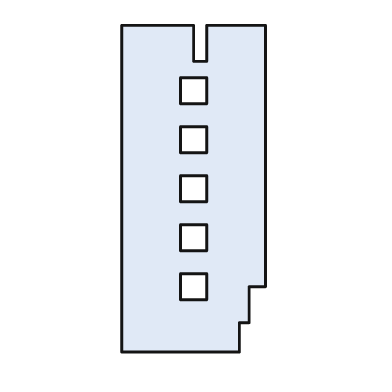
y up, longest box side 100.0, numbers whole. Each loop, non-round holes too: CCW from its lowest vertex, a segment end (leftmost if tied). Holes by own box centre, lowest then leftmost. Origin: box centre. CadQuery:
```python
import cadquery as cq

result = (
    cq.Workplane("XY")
    .moveTo(-22.0, -50.0)
    .lineTo(14.0, -50.0)
    .lineTo(14.0, -41.0)
    .lineTo(17.0, -41.0)
    .lineTo(17.0, -30.0)
    .lineTo(22.0, -30.0)
    .lineTo(22.0, 50.0)
    .lineTo(4.0, 50.0)
    .lineTo(4.0, 39.0)
    .lineTo(0.0, 39.0)
    .lineTo(0.0, 50.0)
    .lineTo(-22.0, 50.0)
    .close()
    .moveTo(-4.0, -34.0)
    .lineTo(4.0, -34.0)
    .lineTo(4.0, -26.0)
    .lineTo(-4.0, -26.0)
    .close()
    .moveTo(-4.0, -19.0)
    .lineTo(4.0, -19.0)
    .lineTo(4.0, -11.0)
    .lineTo(-4.0, -11.0)
    .close()
    .moveTo(-4.0, -4.0)
    .lineTo(4.0, -4.0)
    .lineTo(4.0, 4.0)
    .lineTo(-4.0, 4.0)
    .close()
    .moveTo(-4.0, 11.0)
    .lineTo(4.0, 11.0)
    .lineTo(4.0, 19.0)
    .lineTo(-4.0, 19.0)
    .close()
    .moveTo(-4.0, 26.0)
    .lineTo(4.0, 26.0)
    .lineTo(4.0, 34.0)
    .lineTo(-4.0, 34.0)
    .close()
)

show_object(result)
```